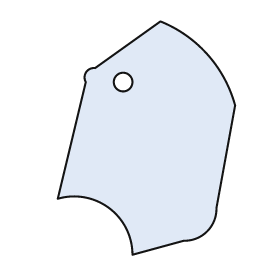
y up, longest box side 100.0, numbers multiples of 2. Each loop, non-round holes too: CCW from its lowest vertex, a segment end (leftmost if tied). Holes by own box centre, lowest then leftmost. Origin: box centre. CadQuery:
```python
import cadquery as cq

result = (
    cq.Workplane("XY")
    .moveTo(-6.0, -50.0)
    .lineTo(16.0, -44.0)
    .threePointArc((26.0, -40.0), (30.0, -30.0))
    .lineTo(38.0, 14.0)
    .threePointArc((26.0, 36.0), (6.0, 50.0))
    .lineTo(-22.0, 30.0)
    .threePointArc((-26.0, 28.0), (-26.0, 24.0))
    .lineTo(-38.0, -26.0)
    .threePointArc((-16.0, -30.0), (-6.0, -50.0))
    .close()
    .moveTo(-10.0, 24.0)
    .circle(4.0)
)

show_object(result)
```